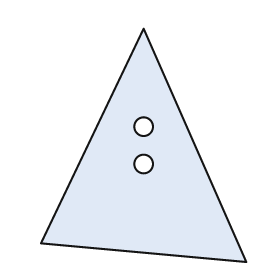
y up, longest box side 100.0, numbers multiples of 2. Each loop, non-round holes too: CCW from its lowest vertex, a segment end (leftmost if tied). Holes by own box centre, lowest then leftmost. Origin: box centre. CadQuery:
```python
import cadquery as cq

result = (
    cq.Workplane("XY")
    .moveTo(44.0, -50.0)
    .lineTo(0.0, 50.0)
    .lineTo(-44.0, -42.0)
    .close()
    .moveTo(0.0, -8.0)
    .circle(4.0)
    .moveTo(0.0, 8.0)
    .circle(4.0)
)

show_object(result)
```